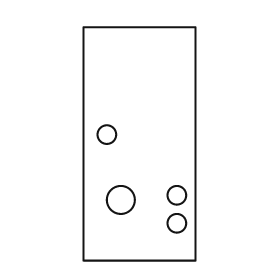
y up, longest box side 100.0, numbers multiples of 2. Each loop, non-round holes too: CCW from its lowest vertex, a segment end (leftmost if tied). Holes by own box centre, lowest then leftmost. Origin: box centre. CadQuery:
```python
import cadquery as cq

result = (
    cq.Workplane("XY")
    .moveTo(-24.0, -50.0)
    .lineTo(24.0, -50.0)
    .lineTo(24.0, 50.0)
    .lineTo(-24.0, 50.0)
    .close()
    .moveTo(16.0, -34.0)
    .circle(4.0)
    .moveTo(-8.0, -24.0)
    .circle(6.0)
    .moveTo(16.0, -22.0)
    .circle(4.0)
    .moveTo(-14.0, 4.0)
    .circle(4.0)
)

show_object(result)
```